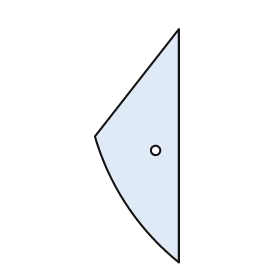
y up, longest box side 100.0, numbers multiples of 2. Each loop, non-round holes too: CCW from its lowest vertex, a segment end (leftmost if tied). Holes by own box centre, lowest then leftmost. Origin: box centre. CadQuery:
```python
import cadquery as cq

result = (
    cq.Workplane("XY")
    .moveTo(18.0, -50.0)
    .lineTo(18.0, 50.0)
    .lineTo(-18.0, 4.0)
    .threePointArc((-4.0, -26.0), (18.0, -50.0))
    .close()
    .moveTo(8.0, -2.0)
    .circle(2.0)
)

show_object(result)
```